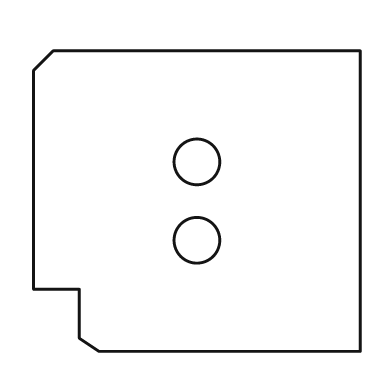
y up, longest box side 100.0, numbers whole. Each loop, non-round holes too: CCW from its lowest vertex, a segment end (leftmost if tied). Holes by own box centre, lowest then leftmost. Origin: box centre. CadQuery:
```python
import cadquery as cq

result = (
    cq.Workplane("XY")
    .moveTo(-30.0, -46.0)
    .lineTo(50.0, -46.0)
    .lineTo(50.0, 46.0)
    .lineTo(-44.0, 46.0)
    .lineTo(-50.0, 40.0)
    .lineTo(-50.0, -27.0)
    .lineTo(-36.0, -27.0)
    .lineTo(-36.0, -42.0)
    .close()
    .moveTo(0.0, -12.0)
    .circle(7.0)
    .moveTo(0.0, 12.0)
    .circle(7.0)
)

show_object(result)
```